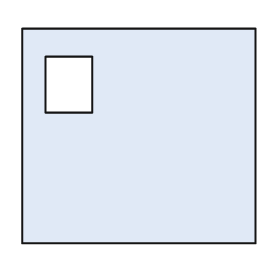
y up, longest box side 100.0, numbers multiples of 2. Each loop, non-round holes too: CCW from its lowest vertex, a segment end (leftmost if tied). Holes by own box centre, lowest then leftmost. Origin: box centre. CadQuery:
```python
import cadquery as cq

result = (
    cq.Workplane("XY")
    .moveTo(-50.0, -46.0)
    .lineTo(50.0, -46.0)
    .lineTo(50.0, 46.0)
    .lineTo(-50.0, 46.0)
    .close()
    .moveTo(-40.0, 10.0)
    .lineTo(-20.0, 10.0)
    .lineTo(-20.0, 34.0)
    .lineTo(-40.0, 34.0)
    .close()
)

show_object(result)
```